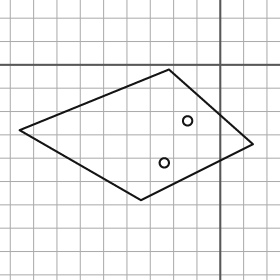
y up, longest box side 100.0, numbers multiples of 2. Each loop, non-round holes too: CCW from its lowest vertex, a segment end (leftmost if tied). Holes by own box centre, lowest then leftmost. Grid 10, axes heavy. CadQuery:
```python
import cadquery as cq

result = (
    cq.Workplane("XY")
    .moveTo(-34.0, -58.0)
    .lineTo(14.0, -34.0)
    .lineTo(-22.0, -2.0)
    .lineTo(-86.0, -28.0)
    .close()
    .moveTo(-24.0, -42.0)
    .circle(2.0)
    .moveTo(-14.0, -24.0)
    .circle(2.0)
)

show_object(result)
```